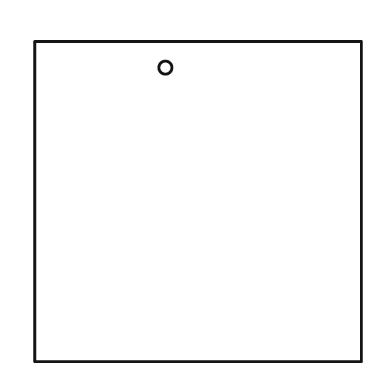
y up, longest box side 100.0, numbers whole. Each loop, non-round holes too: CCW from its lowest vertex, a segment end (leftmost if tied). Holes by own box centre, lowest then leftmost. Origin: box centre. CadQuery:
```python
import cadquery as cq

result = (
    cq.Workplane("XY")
    .moveTo(-50.0, -49.0)
    .lineTo(50.0, -49.0)
    .lineTo(50.0, 49.0)
    .lineTo(-50.0, 49.0)
    .close()
    .moveTo(-10.0, 41.0)
    .circle(2.0)
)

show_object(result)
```